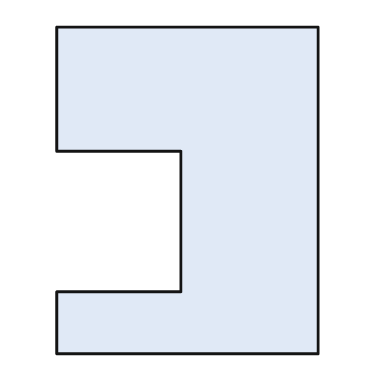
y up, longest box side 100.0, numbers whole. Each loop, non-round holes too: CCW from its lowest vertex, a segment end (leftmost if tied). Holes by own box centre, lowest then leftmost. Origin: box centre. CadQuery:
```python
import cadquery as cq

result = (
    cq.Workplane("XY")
    .moveTo(-40.0, -50.0)
    .lineTo(40.0, -50.0)
    .lineTo(40.0, 50.0)
    .lineTo(-40.0, 50.0)
    .lineTo(-40.0, 12.0)
    .lineTo(-2.0, 12.0)
    .lineTo(-2.0, -31.0)
    .lineTo(-40.0, -31.0)
    .close()
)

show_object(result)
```